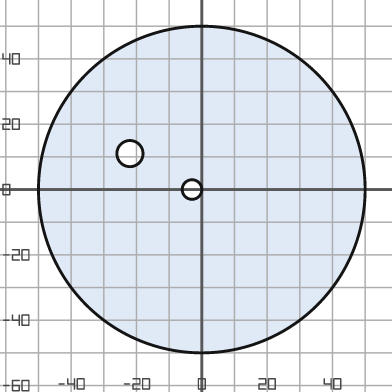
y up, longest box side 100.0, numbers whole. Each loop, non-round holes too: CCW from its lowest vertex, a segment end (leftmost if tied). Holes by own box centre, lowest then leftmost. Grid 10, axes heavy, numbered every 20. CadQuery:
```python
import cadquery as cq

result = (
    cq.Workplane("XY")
    .moveTo(0.0, 0.0)
    .circle(50.0)
    .moveTo(-3.0, 0.0)
    .circle(3.0)
    .moveTo(-22.0, 11.0)
    .circle(4.0)
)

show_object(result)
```